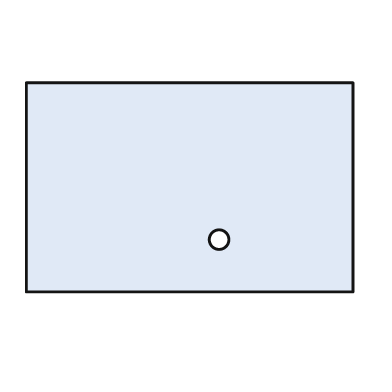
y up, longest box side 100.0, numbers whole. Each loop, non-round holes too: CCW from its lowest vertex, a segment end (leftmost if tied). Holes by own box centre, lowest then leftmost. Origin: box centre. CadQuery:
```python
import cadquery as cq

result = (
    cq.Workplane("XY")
    .moveTo(-50.0, -32.0)
    .lineTo(50.0, -32.0)
    .lineTo(50.0, 32.0)
    .lineTo(-50.0, 32.0)
    .close()
    .moveTo(9.0, -16.0)
    .circle(3.0)
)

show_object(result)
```